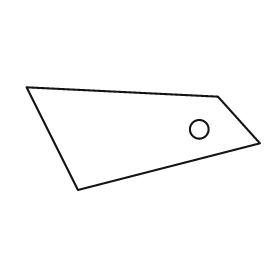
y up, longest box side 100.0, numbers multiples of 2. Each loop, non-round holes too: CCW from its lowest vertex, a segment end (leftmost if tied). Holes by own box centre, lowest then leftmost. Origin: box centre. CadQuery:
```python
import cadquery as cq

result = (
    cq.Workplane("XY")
    .moveTo(-28.0, -22.0)
    .lineTo(50.0, -2.0)
    .lineTo(32.0, 18.0)
    .lineTo(-50.0, 22.0)
    .close()
    .moveTo(24.0, 4.0)
    .circle(4.0)
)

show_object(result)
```